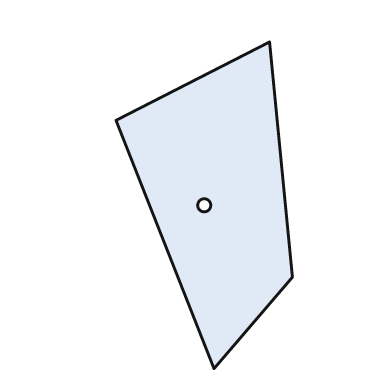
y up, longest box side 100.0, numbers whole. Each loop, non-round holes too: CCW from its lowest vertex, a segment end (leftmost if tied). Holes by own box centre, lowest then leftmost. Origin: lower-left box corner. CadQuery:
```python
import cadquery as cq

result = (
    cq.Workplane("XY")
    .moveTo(30.0, 0.0)
    .lineTo(54.0, 28.0)
    .lineTo(47.0, 100.0)
    .lineTo(0.0, 76.0)
    .close()
    .moveTo(27.0, 50.0)
    .circle(2.0)
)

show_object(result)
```